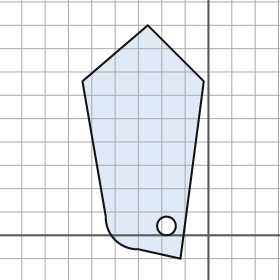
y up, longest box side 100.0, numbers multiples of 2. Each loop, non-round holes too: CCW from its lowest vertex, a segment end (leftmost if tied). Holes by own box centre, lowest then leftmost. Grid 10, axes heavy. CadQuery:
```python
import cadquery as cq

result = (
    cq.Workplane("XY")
    .moveTo(-12.0, -10.0)
    .lineTo(-2.0, 66.0)
    .lineTo(-26.0, 90.0)
    .lineTo(-54.0, 66.0)
    .lineTo(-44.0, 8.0)
    .threePointArc((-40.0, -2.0), (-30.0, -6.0))
    .close()
    .moveTo(-18.0, 4.0)
    .circle(4.0)
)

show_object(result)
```